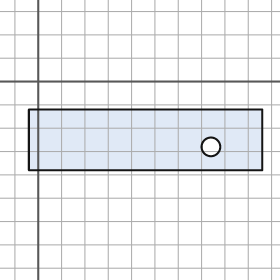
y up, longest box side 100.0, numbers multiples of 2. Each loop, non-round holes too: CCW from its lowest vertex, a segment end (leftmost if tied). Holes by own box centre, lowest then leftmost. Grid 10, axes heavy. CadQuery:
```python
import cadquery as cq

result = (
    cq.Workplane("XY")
    .moveTo(-4.0, -38.0)
    .lineTo(96.0, -38.0)
    .lineTo(96.0, -12.0)
    .lineTo(-4.0, -12.0)
    .close()
    .moveTo(74.0, -28.0)
    .circle(4.0)
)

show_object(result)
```